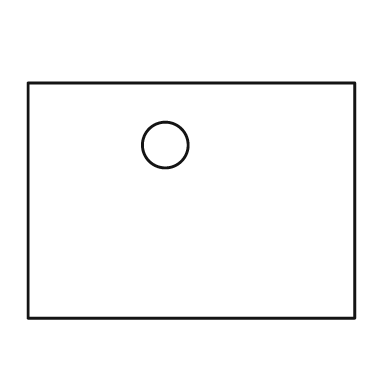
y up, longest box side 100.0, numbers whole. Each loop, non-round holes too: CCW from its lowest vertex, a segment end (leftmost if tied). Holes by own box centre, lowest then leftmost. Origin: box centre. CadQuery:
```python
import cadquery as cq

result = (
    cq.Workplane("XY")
    .moveTo(-50.0, -36.0)
    .lineTo(50.0, -36.0)
    .lineTo(50.0, 36.0)
    .lineTo(-50.0, 36.0)
    .close()
    .moveTo(-8.0, 17.0)
    .circle(7.0)
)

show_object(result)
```